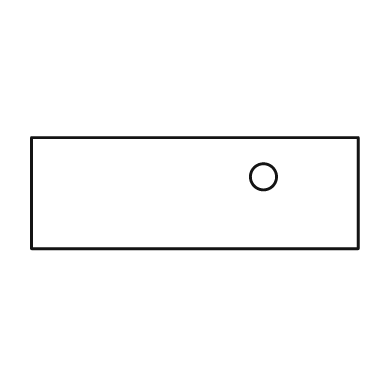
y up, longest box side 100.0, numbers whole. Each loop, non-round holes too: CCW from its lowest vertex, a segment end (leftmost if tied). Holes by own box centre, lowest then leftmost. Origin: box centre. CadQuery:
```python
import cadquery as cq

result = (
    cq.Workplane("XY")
    .moveTo(-50.0, -17.0)
    .lineTo(50.0, -17.0)
    .lineTo(50.0, 17.0)
    .lineTo(-50.0, 17.0)
    .close()
    .moveTo(21.0, 5.0)
    .circle(4.0)
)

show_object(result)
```